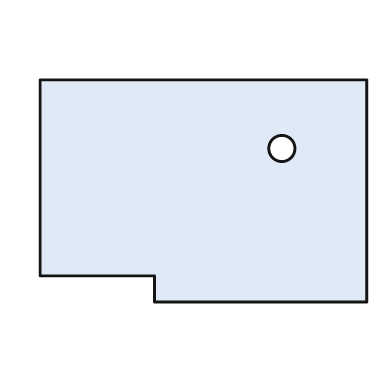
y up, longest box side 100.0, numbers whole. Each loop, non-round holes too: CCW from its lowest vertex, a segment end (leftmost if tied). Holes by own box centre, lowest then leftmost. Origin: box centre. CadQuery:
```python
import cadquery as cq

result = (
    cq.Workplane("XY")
    .moveTo(-15.0, -34.0)
    .lineTo(50.0, -34.0)
    .lineTo(50.0, 34.0)
    .lineTo(-50.0, 34.0)
    .lineTo(-50.0, -26.0)
    .lineTo(-15.0, -26.0)
    .close()
    .moveTo(24.0, 13.0)
    .circle(4.0)
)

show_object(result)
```